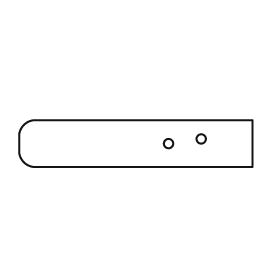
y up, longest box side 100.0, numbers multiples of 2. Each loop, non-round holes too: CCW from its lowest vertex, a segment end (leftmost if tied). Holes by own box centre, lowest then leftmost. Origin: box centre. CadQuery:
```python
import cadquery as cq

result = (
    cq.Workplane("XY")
    .moveTo(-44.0, -10.0)
    .lineTo(50.0, -10.0)
    .lineTo(50.0, 10.0)
    .lineTo(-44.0, 10.0)
    .threePointArc((-48.0, 8.0), (-50.0, 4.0))
    .lineTo(-50.0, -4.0)
    .threePointArc((-48.0, -8.0), (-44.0, -10.0))
    .close()
    .moveTo(14.0, 0.0)
    .circle(2.0)
    .moveTo(28.0, 2.0)
    .circle(2.0)
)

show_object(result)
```